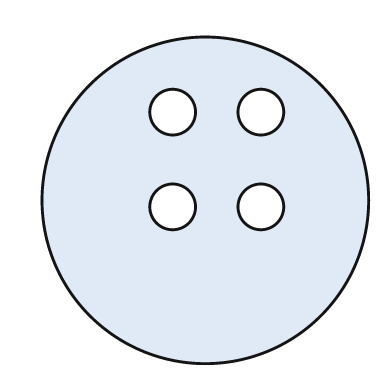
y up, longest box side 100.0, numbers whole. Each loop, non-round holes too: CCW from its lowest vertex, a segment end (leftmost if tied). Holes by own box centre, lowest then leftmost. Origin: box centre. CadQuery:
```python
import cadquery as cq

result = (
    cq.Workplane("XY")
    .moveTo(0.0, 0.0)
    .circle(50.0)
    .moveTo(-10.0, -2.0)
    .circle(7.0)
    .moveTo(17.0, -2.0)
    .circle(7.0)
    .moveTo(-10.0, 27.0)
    .circle(7.0)
    .moveTo(17.0, 27.0)
    .circle(7.0)
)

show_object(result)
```